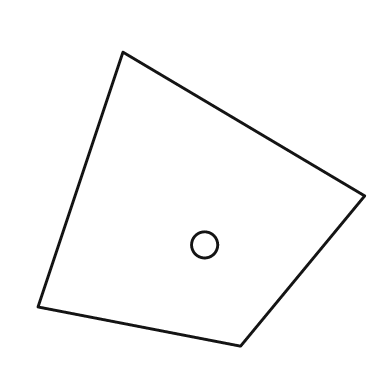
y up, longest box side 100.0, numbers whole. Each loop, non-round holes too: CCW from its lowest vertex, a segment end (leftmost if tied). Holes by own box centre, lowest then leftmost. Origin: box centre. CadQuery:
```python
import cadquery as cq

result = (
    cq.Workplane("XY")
    .moveTo(12.0, -45.0)
    .lineTo(50.0, 1.0)
    .lineTo(-24.0, 45.0)
    .lineTo(-50.0, -33.0)
    .close()
    .moveTo(1.0, -14.0)
    .circle(4.0)
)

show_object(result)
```